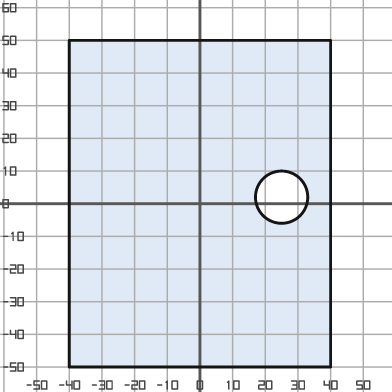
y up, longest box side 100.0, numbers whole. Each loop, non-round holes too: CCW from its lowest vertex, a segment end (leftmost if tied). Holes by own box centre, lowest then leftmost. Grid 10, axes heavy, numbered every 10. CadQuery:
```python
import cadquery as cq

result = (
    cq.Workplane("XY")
    .moveTo(-40.0, -50.0)
    .lineTo(40.0, -50.0)
    .lineTo(40.0, 50.0)
    .lineTo(-40.0, 50.0)
    .close()
    .moveTo(25.0, 2.0)
    .circle(8.0)
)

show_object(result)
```